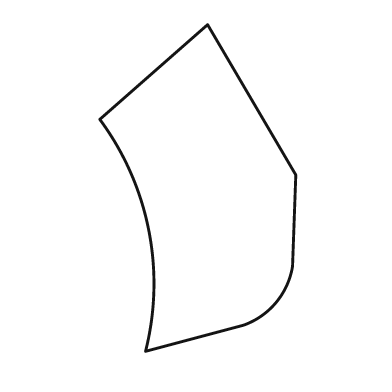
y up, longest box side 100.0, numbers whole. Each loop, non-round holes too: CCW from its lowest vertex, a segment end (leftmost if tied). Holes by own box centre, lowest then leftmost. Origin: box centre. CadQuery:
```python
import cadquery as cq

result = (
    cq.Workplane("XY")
    .moveTo(-16.0, -50.0)
    .lineTo(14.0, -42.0)
    .threePointArc((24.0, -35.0), (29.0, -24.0))
    .lineTo(30.0, 4.0)
    .lineTo(3.0, 50.0)
    .lineTo(-30.0, 21.0)
    .threePointArc((-15.0, -13.0), (-16.0, -50.0))
    .close()
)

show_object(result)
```